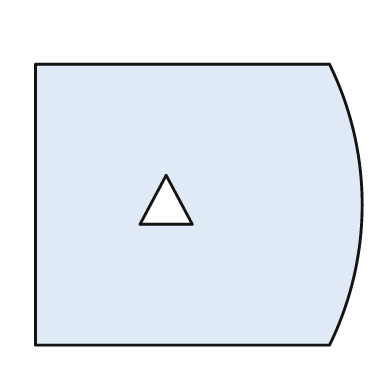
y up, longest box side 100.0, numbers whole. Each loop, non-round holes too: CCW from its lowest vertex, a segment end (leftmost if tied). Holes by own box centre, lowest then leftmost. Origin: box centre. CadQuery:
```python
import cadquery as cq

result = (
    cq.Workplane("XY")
    .moveTo(-50.0, -43.0)
    .lineTo(40.0, -43.0)
    .threePointArc((50.0, 0.0), (40.0, 43.0))
    .lineTo(-50.0, 43.0)
    .close()
    .moveTo(-18.0, -6.0)
    .lineTo(-2.0, -6.0)
    .lineTo(-10.0, 9.0)
    .close()
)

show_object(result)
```